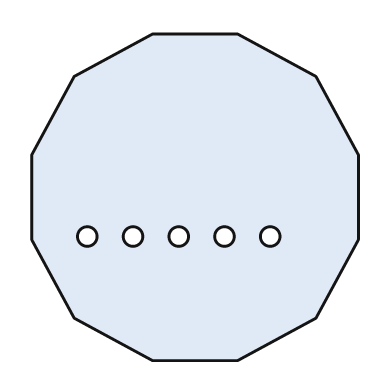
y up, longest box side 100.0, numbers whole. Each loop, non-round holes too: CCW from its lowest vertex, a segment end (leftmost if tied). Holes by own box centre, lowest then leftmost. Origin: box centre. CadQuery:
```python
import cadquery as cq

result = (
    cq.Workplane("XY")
    .moveTo(-13.0, -50.0)
    .lineTo(13.0, -50.0)
    .lineTo(37.0, -37.0)
    .lineTo(50.0, -13.0)
    .lineTo(50.0, 13.0)
    .lineTo(37.0, 37.0)
    .lineTo(13.0, 50.0)
    .lineTo(-13.0, 50.0)
    .lineTo(-37.0, 37.0)
    .lineTo(-50.0, 13.0)
    .lineTo(-50.0, -13.0)
    .lineTo(-37.0, -37.0)
    .close()
    .moveTo(-33.0, -12.0)
    .circle(3.0)
    .moveTo(-19.0, -12.0)
    .circle(3.0)
    .moveTo(-5.0, -12.0)
    .circle(3.0)
    .moveTo(9.0, -12.0)
    .circle(3.0)
    .moveTo(23.0, -12.0)
    .circle(3.0)
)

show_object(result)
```